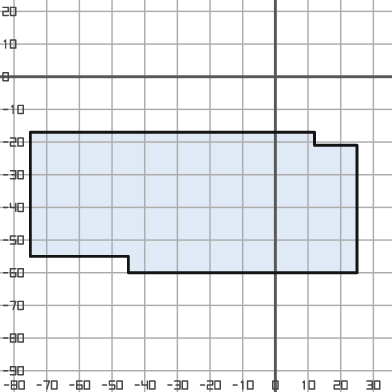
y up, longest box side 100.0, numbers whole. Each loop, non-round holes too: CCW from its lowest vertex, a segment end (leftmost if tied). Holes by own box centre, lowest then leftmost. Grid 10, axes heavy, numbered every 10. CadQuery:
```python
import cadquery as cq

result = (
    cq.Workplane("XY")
    .moveTo(-45.0, -60.0)
    .lineTo(25.0, -60.0)
    .lineTo(25.0, -21.0)
    .lineTo(12.0, -21.0)
    .lineTo(12.0, -17.0)
    .lineTo(-75.0, -17.0)
    .lineTo(-75.0, -55.0)
    .lineTo(-45.0, -55.0)
    .close()
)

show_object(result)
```